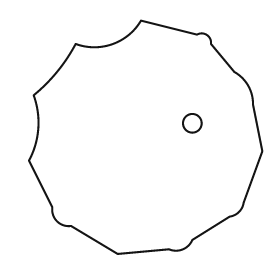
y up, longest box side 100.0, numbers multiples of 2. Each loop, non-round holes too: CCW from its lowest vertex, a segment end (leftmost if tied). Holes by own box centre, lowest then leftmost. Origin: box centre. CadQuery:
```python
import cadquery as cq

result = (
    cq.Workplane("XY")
    .moveTo(-12.0, -50.0)
    .lineTo(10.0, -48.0)
    .threePointArc((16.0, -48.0), (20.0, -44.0))
    .lineTo(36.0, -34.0)
    .threePointArc((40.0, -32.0), (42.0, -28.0))
    .lineTo(50.0, -6.0)
    .lineTo(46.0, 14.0)
    .threePointArc((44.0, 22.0), (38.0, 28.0))
    .lineTo(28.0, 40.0)
    .threePointArc((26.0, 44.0), (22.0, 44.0))
    .lineTo(-2.0, 50.0)
    .threePointArc((-14.0, 40.0), (-30.0, 40.0))
    .threePointArc((-38.0, 28.0), (-48.0, 18.0))
    .threePointArc((-46.0, 4.0), (-50.0, -10.0))
    .lineTo(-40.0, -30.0)
    .threePointArc((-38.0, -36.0), (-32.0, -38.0))
    .close()
    .moveTo(20.0, 6.0)
    .circle(4.0)
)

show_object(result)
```